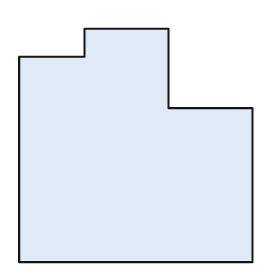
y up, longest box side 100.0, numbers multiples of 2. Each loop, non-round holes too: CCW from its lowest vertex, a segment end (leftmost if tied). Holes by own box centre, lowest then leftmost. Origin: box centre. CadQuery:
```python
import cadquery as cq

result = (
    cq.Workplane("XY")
    .moveTo(-50.0, -50.0)
    .lineTo(50.0, -50.0)
    .lineTo(50.0, 16.0)
    .lineTo(14.0, 16.0)
    .lineTo(14.0, 50.0)
    .lineTo(-22.0, 50.0)
    .lineTo(-22.0, 38.0)
    .lineTo(-50.0, 38.0)
    .close()
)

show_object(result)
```